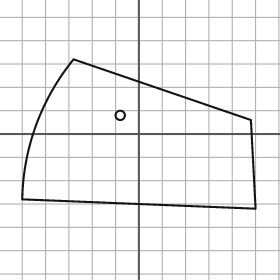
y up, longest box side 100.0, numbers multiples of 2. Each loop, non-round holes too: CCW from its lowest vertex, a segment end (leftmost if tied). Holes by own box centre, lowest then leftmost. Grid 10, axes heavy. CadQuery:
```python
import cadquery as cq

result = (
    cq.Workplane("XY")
    .moveTo(50.0, -32.0)
    .lineTo(48.0, 6.0)
    .lineTo(-28.0, 32.0)
    .threePointArc((-44.0, 4.0), (-50.0, -28.0))
    .close()
    .moveTo(-8.0, 8.0)
    .circle(2.0)
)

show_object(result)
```